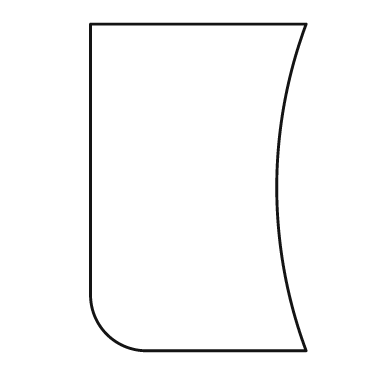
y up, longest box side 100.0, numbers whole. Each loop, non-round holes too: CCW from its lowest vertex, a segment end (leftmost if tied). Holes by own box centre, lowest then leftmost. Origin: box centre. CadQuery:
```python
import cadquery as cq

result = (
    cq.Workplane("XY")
    .moveTo(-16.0, -50.0)
    .lineTo(33.0, -50.0)
    .threePointArc((24.0, 0.0), (33.0, 50.0))
    .lineTo(-33.0, 50.0)
    .lineTo(-33.0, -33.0)
    .threePointArc((-28.0, -45.0), (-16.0, -50.0))
    .close()
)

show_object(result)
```